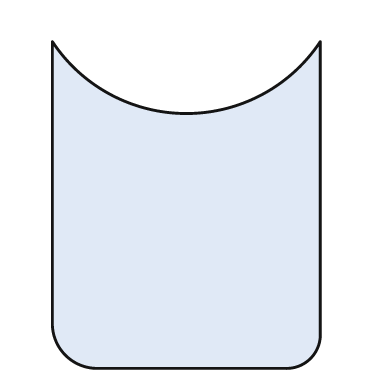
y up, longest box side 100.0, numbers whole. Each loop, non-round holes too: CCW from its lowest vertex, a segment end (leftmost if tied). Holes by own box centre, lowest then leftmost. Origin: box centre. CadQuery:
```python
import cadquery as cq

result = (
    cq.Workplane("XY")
    .moveTo(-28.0, -50.0)
    .lineTo(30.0, -50.0)
    .threePointArc((38.0, -47.0), (41.0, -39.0))
    .lineTo(41.0, 50.0)
    .threePointArc((0.0, 28.0), (-41.0, 50.0))
    .lineTo(-41.0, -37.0)
    .threePointArc((-37.0, -46.0), (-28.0, -50.0))
    .close()
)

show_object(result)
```